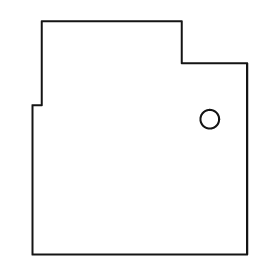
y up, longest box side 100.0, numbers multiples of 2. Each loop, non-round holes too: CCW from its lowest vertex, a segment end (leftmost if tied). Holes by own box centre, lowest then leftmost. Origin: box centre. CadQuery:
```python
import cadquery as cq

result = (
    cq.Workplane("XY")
    .moveTo(-46.0, -50.0)
    .lineTo(46.0, -50.0)
    .lineTo(46.0, 32.0)
    .lineTo(18.0, 32.0)
    .lineTo(18.0, 50.0)
    .lineTo(-42.0, 50.0)
    .lineTo(-42.0, 14.0)
    .lineTo(-46.0, 14.0)
    .close()
    .moveTo(30.0, 8.0)
    .circle(4.0)
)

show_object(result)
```